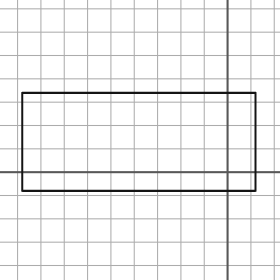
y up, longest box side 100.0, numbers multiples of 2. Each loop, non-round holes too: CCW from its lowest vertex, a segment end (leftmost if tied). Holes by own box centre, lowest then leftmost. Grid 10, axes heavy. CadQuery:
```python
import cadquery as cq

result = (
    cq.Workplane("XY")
    .moveTo(-88.0, -8.0)
    .lineTo(12.0, -8.0)
    .lineTo(12.0, 34.0)
    .lineTo(-88.0, 34.0)
    .close()
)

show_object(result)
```